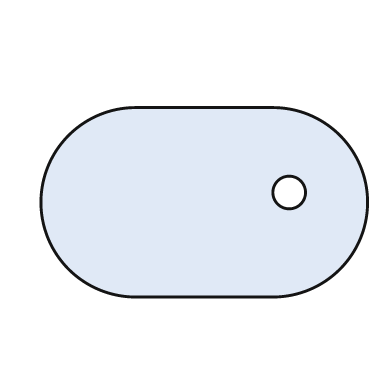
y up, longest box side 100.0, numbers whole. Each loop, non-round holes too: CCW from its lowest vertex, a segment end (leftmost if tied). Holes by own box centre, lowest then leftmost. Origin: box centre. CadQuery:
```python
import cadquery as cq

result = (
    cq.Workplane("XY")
    .moveTo(-21.0, -29.0)
    .lineTo(21.0, -29.0)
    .threePointArc((50.0, 0.0), (21.0, 29.0))
    .lineTo(-21.0, 29.0)
    .threePointArc((-50.0, 0.0), (-21.0, -29.0))
    .close()
    .moveTo(26.0, 3.0)
    .circle(5.0)
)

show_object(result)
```